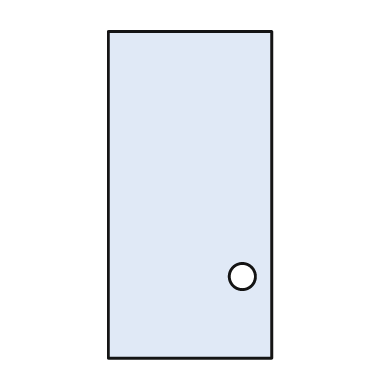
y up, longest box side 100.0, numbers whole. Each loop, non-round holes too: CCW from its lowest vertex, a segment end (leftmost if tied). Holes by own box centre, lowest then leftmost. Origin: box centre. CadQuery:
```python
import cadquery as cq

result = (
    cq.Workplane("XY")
    .moveTo(-25.0, -50.0)
    .lineTo(25.0, -50.0)
    .lineTo(25.0, 50.0)
    .lineTo(-25.0, 50.0)
    .close()
    .moveTo(16.0, -25.0)
    .circle(4.0)
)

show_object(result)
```